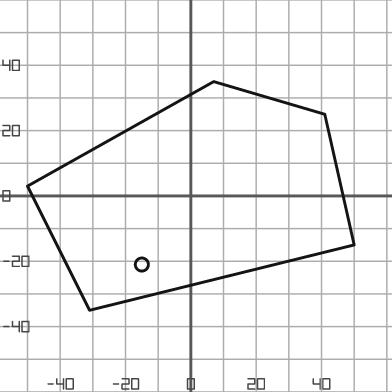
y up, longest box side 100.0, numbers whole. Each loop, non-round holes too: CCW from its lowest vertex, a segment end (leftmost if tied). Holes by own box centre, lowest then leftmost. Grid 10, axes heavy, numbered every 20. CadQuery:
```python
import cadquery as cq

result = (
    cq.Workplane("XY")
    .moveTo(-31.0, -35.0)
    .lineTo(50.0, -15.0)
    .lineTo(41.0, 25.0)
    .lineTo(7.0, 35.0)
    .lineTo(-50.0, 3.0)
    .close()
    .moveTo(-15.0, -21.0)
    .circle(2.0)
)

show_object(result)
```